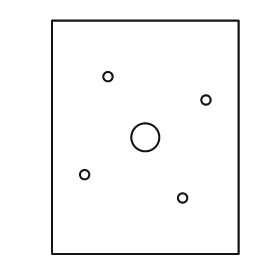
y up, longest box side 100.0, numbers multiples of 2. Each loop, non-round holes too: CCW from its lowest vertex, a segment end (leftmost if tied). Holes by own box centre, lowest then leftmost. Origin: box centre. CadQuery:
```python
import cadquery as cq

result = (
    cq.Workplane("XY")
    .moveTo(-40.0, -50.0)
    .lineTo(40.0, -50.0)
    .lineTo(40.0, 50.0)
    .lineTo(-40.0, 50.0)
    .close()
    .moveTo(16.0, -26.0)
    .circle(2.0)
    .moveTo(-26.0, -16.0)
    .circle(2.0)
    .moveTo(0.0, 0.0)
    .circle(6.0)
    .moveTo(26.0, 16.0)
    .circle(2.0)
    .moveTo(-16.0, 26.0)
    .circle(2.0)
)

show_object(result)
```